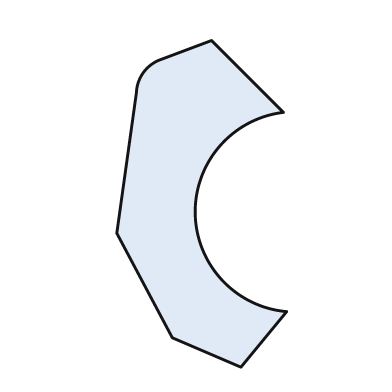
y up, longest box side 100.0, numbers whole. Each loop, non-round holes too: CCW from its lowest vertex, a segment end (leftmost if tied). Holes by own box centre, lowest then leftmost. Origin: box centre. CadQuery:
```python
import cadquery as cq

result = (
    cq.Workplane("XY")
    .moveTo(12.0, -50.0)
    .lineTo(26.0, -33.0)
    .threePointArc((-2.0, -3.0), (25.0, 28.0))
    .lineTo(3.0, 50.0)
    .lineTo(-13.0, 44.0)
    .threePointArc((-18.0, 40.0), (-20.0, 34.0))
    .lineTo(-26.0, -9.0)
    .lineTo(-9.0, -41.0)
    .close()
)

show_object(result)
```